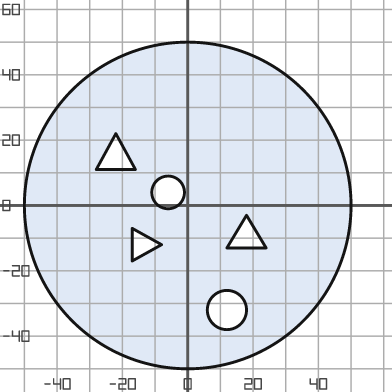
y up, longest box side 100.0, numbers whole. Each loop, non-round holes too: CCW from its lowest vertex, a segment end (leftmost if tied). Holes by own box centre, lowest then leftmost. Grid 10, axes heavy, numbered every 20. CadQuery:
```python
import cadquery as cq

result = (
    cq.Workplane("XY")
    .moveTo(0.0, 0.0)
    .circle(50.0)
    .moveTo(12.0, -32.0)
    .circle(6.0)
    .moveTo(-17.0, -17.0)
    .lineTo(-8.0, -12.0)
    .lineTo(-17.0, -7.0)
    .close()
    .moveTo(12.0, -13.0)
    .lineTo(24.0, -13.0)
    .lineTo(18.0, -3.0)
    .close()
    .moveTo(-6.0, 4.0)
    .circle(5.0)
    .moveTo(-28.0, 11.0)
    .lineTo(-16.0, 11.0)
    .lineTo(-22.0, 22.0)
    .close()
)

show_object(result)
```